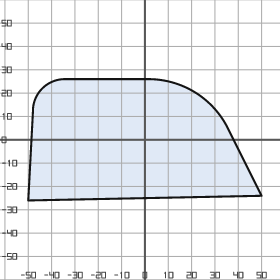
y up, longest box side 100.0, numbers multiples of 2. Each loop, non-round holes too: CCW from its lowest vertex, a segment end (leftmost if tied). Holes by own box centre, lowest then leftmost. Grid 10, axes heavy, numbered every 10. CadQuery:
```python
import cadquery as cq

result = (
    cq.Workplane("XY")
    .moveTo(-50.0, -26.0)
    .lineTo(50.0, -24.0)
    .lineTo(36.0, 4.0)
    .threePointArc((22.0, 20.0), (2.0, 26.0))
    .lineTo(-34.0, 26.0)
    .threePointArc((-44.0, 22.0), (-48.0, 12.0))
    .close()
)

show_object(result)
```